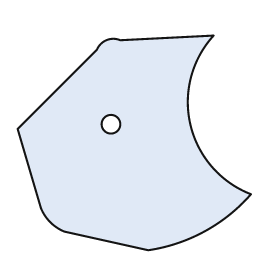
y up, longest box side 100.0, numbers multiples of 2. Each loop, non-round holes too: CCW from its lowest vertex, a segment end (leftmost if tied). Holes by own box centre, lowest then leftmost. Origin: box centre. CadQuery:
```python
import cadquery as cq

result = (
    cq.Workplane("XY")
    .moveTo(6.0, -46.0)
    .threePointArc((30.0, -38.0), (50.0, -22.0))
    .threePointArc((24.0, 8.0), (34.0, 46.0))
    .lineTo(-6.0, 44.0)
    .threePointArc((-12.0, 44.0), (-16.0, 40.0))
    .lineTo(-50.0, 6.0)
    .lineTo(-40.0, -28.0)
    .threePointArc((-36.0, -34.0), (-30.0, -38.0))
    .close()
    .moveTo(-10.0, 8.0)
    .circle(4.0)
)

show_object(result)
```